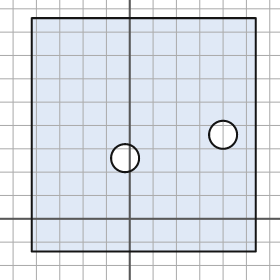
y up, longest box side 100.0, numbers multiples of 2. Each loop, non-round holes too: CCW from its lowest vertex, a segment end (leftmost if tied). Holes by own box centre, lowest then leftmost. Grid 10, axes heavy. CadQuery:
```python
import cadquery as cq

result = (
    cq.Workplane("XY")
    .moveTo(-42.0, -14.0)
    .lineTo(54.0, -14.0)
    .lineTo(54.0, 86.0)
    .lineTo(-42.0, 86.0)
    .close()
    .moveTo(-2.0, 26.0)
    .circle(6.0)
    .moveTo(40.0, 36.0)
    .circle(6.0)
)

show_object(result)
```